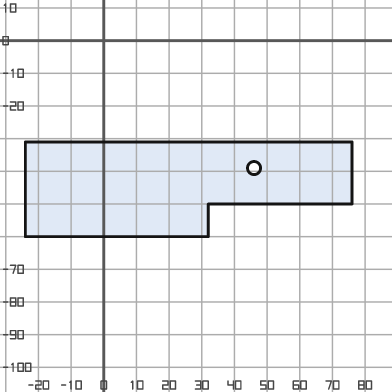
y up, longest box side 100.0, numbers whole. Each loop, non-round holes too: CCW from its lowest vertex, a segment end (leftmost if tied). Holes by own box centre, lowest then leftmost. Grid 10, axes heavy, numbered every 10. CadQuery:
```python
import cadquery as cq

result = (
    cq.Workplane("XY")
    .moveTo(-24.0, -60.0)
    .lineTo(32.0, -60.0)
    .lineTo(32.0, -50.0)
    .lineTo(76.0, -50.0)
    .lineTo(76.0, -31.0)
    .lineTo(-24.0, -31.0)
    .close()
    .moveTo(46.0, -39.0)
    .circle(2.0)
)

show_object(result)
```